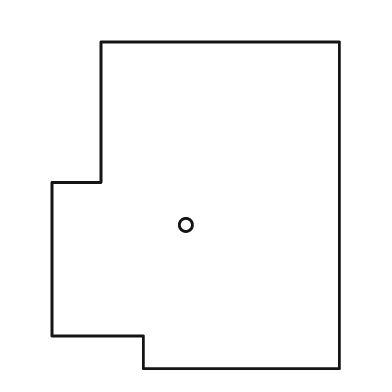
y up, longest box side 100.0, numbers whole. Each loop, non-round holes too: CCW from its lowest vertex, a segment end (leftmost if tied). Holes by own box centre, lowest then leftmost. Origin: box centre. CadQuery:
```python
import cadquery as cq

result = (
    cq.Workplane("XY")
    .moveTo(-16.0, -50.0)
    .lineTo(44.0, -50.0)
    .lineTo(44.0, 50.0)
    .lineTo(-29.0, 50.0)
    .lineTo(-29.0, 7.0)
    .lineTo(-44.0, 7.0)
    .lineTo(-44.0, -40.0)
    .lineTo(-16.0, -40.0)
    .close()
    .moveTo(-3.0, -6.0)
    .circle(2.0)
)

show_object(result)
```